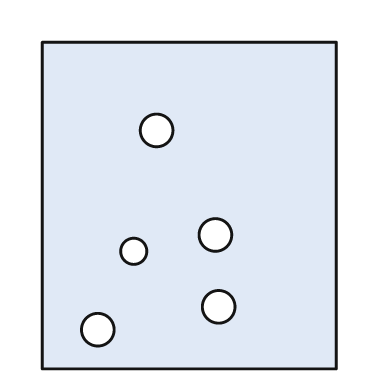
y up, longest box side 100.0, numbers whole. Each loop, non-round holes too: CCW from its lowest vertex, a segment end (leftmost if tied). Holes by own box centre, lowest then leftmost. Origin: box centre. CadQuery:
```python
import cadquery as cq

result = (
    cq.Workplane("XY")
    .moveTo(-45.0, -50.0)
    .lineTo(45.0, -50.0)
    .lineTo(45.0, 50.0)
    .lineTo(-45.0, 50.0)
    .close()
    .moveTo(-28.0, -38.0)
    .circle(5.0)
    .moveTo(9.0, -31.0)
    .circle(5.0)
    .moveTo(-17.0, -14.0)
    .circle(4.0)
    .moveTo(8.0, -9.0)
    .circle(5.0)
    .moveTo(-10.0, 23.0)
    .circle(5.0)
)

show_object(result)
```